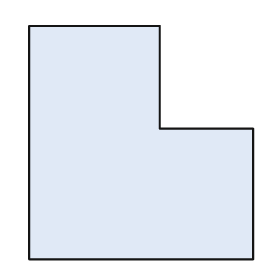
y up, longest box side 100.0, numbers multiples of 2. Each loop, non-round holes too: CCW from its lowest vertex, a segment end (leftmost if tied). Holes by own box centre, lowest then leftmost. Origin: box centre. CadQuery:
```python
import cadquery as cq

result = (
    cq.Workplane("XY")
    .moveTo(-48.0, -50.0)
    .lineTo(48.0, -50.0)
    .lineTo(48.0, 6.0)
    .lineTo(8.0, 6.0)
    .lineTo(8.0, 50.0)
    .lineTo(-48.0, 50.0)
    .close()
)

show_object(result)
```